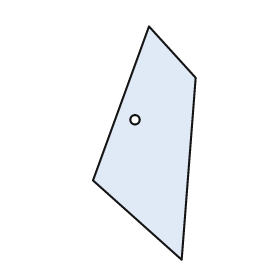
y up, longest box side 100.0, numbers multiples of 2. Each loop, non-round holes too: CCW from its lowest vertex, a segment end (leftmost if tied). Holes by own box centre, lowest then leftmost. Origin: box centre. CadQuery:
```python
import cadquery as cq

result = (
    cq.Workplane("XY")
    .moveTo(16.0, -50.0)
    .lineTo(22.0, 28.0)
    .lineTo(2.0, 50.0)
    .lineTo(-22.0, -16.0)
    .close()
    .moveTo(-4.0, 10.0)
    .circle(2.0)
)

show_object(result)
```